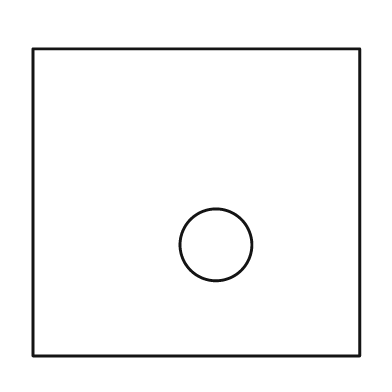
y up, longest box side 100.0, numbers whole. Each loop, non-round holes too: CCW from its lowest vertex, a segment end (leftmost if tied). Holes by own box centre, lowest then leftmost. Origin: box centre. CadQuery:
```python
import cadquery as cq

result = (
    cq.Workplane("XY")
    .moveTo(-50.0, -47.0)
    .lineTo(50.0, -47.0)
    .lineTo(50.0, 47.0)
    .lineTo(-50.0, 47.0)
    .close()
    .moveTo(6.0, -13.0)
    .circle(11.0)
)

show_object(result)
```